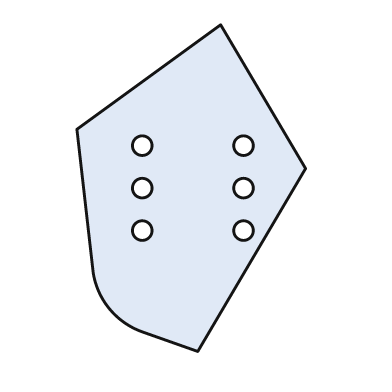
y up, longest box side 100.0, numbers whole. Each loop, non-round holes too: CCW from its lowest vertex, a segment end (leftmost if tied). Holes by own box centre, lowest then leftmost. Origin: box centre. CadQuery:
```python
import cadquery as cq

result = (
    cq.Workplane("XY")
    .moveTo(2.0, -50.0)
    .lineTo(35.0, 6.0)
    .lineTo(9.0, 50.0)
    .lineTo(-35.0, 18.0)
    .lineTo(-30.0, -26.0)
    .threePointArc((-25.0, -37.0), (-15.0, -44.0))
    .close()
    .moveTo(-15.0, -13.0)
    .circle(3.0)
    .moveTo(16.0, -13.0)
    .circle(3.0)
    .moveTo(-15.0, 0.0)
    .circle(3.0)
    .moveTo(16.0, 0.0)
    .circle(3.0)
    .moveTo(-15.0, 13.0)
    .circle(3.0)
    .moveTo(16.0, 13.0)
    .circle(3.0)
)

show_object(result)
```